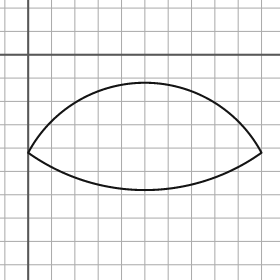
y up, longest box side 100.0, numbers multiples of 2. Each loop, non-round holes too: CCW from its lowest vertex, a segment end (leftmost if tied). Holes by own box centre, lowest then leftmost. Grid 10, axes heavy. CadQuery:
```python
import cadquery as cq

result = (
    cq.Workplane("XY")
    .moveTo(0.0, -42.0)
    .threePointArc((50.0, -58.0), (100.0, -42.0))
    .threePointArc((50.0, -12.0), (0.0, -42.0))
    .close()
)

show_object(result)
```